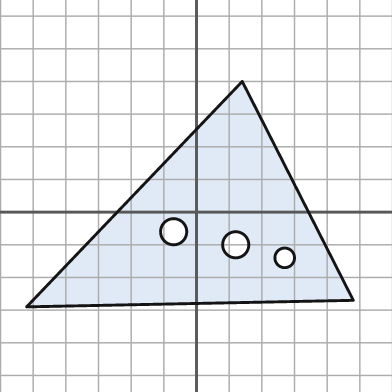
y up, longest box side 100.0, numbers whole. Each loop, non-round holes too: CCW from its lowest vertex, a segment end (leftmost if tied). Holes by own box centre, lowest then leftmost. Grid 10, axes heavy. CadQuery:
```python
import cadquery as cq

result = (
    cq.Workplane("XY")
    .moveTo(-52.0, -29.0)
    .lineTo(48.0, -27.0)
    .lineTo(14.0, 40.0)
    .close()
    .moveTo(27.0, -14.0)
    .circle(3.0)
    .moveTo(12.0, -10.0)
    .circle(4.0)
    .moveTo(-7.0, -6.0)
    .circle(4.0)
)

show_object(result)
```